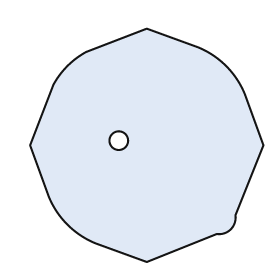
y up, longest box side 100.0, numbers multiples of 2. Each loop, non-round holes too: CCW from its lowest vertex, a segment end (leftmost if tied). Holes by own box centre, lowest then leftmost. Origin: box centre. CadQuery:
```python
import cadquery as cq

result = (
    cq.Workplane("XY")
    .moveTo(0.0, -50.0)
    .lineTo(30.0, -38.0)
    .threePointArc((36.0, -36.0), (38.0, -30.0))
    .lineTo(50.0, 0.0)
    .lineTo(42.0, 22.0)
    .threePointArc((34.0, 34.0), (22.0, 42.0))
    .lineTo(0.0, 50.0)
    .lineTo(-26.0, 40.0)
    .threePointArc((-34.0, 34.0), (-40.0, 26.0))
    .lineTo(-50.0, 0.0)
    .lineTo(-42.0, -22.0)
    .threePointArc((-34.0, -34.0), (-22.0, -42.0))
    .close()
    .moveTo(-12.0, 2.0)
    .circle(4.0)
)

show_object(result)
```